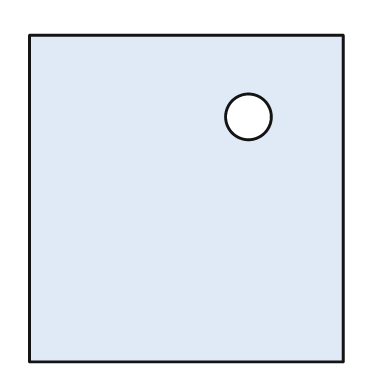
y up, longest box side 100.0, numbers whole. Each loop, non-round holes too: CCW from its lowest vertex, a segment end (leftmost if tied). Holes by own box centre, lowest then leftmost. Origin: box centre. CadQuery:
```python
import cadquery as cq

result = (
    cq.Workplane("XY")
    .moveTo(-48.0, -50.0)
    .lineTo(48.0, -50.0)
    .lineTo(48.0, 50.0)
    .lineTo(-48.0, 50.0)
    .close()
    .moveTo(19.0, 25.0)
    .circle(7.0)
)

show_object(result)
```